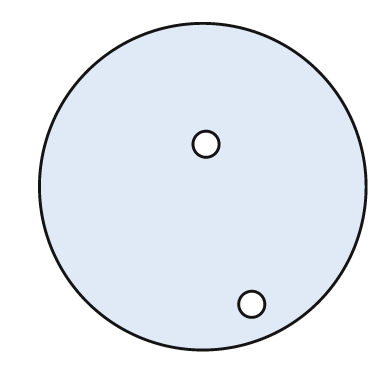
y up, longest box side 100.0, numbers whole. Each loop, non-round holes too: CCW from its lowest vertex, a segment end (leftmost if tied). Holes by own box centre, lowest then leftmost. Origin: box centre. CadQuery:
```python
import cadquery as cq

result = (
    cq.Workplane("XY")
    .moveTo(0.0, 0.0)
    .circle(50.0)
    .moveTo(15.0, -36.0)
    .circle(4.0)
    .moveTo(1.0, 13.0)
    .circle(4.0)
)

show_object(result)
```